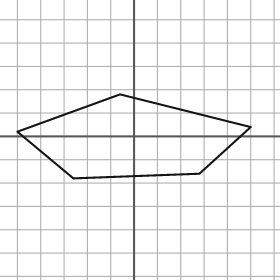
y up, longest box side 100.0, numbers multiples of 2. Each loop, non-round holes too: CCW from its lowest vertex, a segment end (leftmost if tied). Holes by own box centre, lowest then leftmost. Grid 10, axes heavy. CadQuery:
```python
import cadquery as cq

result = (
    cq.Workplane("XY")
    .moveTo(-26.0, -18.0)
    .lineTo(28.0, -16.0)
    .lineTo(50.0, 4.0)
    .lineTo(-6.0, 18.0)
    .lineTo(-50.0, 2.0)
    .close()
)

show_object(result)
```